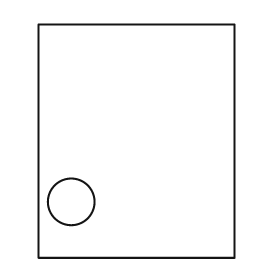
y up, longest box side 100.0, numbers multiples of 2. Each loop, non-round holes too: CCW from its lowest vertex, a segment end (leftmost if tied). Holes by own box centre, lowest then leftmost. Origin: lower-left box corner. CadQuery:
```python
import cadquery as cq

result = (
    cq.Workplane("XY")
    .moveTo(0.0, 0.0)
    .lineTo(84.0, 0.0)
    .lineTo(84.0, 100.0)
    .lineTo(0.0, 100.0)
    .close()
    .moveTo(14.0, 24.0)
    .circle(10.0)
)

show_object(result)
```